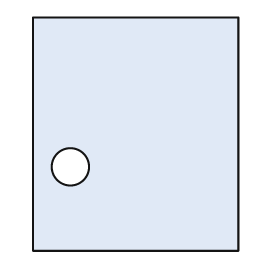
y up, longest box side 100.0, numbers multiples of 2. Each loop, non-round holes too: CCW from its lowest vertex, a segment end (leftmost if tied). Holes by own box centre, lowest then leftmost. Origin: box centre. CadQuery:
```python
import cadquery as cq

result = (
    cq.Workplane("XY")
    .moveTo(-44.0, -50.0)
    .lineTo(44.0, -50.0)
    .lineTo(44.0, 50.0)
    .lineTo(-44.0, 50.0)
    .close()
    .moveTo(-28.0, -14.0)
    .circle(8.0)
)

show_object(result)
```